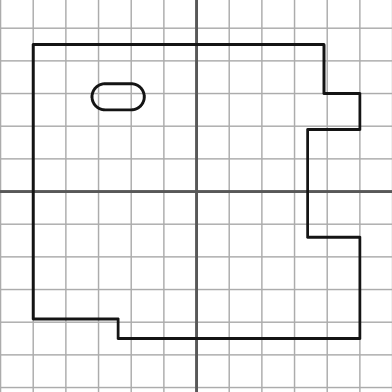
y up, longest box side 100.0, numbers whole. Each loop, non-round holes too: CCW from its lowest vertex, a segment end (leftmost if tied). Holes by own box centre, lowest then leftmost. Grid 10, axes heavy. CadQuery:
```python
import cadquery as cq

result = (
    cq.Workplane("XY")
    .moveTo(-24.0, -45.0)
    .lineTo(50.0, -45.0)
    .lineTo(50.0, -14.0)
    .lineTo(34.0, -14.0)
    .lineTo(34.0, 19.0)
    .lineTo(50.0, 19.0)
    .lineTo(50.0, 30.0)
    .lineTo(39.0, 30.0)
    .lineTo(39.0, 45.0)
    .lineTo(-50.0, 45.0)
    .lineTo(-50.0, -39.0)
    .lineTo(-24.0, -39.0)
    .close()
    .moveTo(-28.0, 25.0)
    .lineTo(-20.0, 25.0)
    .threePointArc((-16.0, 29.0), (-20.0, 33.0))
    .lineTo(-28.0, 33.0)
    .threePointArc((-32.0, 29.0), (-28.0, 25.0))
    .close()
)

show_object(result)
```